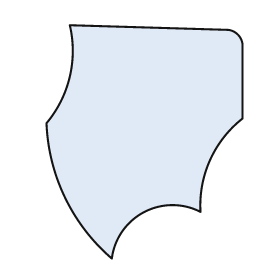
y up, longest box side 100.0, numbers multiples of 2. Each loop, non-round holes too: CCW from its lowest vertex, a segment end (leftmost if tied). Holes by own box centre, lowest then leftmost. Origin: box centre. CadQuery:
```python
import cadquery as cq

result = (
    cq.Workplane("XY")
    .moveTo(-14.0, -50.0)
    .threePointArc((0.0, -30.0), (24.0, -30.0))
    .threePointArc((28.0, -8.0), (42.0, 10.0))
    .lineTo(42.0, 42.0)
    .threePointArc((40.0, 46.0), (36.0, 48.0))
    .lineTo(-32.0, 50.0)
    .threePointArc((-32.0, 28.0), (-42.0, 8.0))
    .threePointArc((-34.0, -24.0), (-14.0, -50.0))
    .close()
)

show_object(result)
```